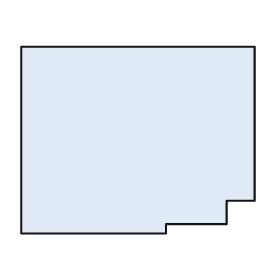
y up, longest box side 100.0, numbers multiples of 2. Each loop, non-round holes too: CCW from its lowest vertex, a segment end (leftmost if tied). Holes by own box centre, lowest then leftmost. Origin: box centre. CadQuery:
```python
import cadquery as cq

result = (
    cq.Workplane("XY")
    .moveTo(-50.0, -40.0)
    .lineTo(12.0, -40.0)
    .lineTo(12.0, -36.0)
    .lineTo(38.0, -36.0)
    .lineTo(38.0, -26.0)
    .lineTo(50.0, -26.0)
    .lineTo(50.0, 40.0)
    .lineTo(-50.0, 40.0)
    .close()
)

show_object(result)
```